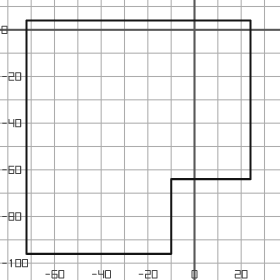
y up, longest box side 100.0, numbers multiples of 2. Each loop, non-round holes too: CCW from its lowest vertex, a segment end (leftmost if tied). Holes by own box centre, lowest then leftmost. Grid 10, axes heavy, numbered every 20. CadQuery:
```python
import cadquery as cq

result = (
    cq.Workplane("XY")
    .moveTo(-72.0, -96.0)
    .lineTo(-10.0, -96.0)
    .lineTo(-10.0, -64.0)
    .lineTo(24.0, -64.0)
    .lineTo(24.0, 4.0)
    .lineTo(-72.0, 4.0)
    .close()
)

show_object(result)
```